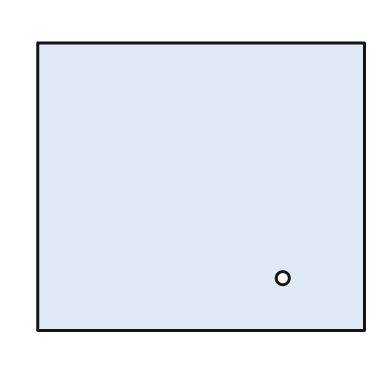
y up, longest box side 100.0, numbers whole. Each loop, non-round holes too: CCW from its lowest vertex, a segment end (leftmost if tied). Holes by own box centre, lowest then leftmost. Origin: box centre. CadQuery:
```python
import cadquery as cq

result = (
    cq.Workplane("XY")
    .moveTo(-50.0, -44.0)
    .lineTo(50.0, -44.0)
    .lineTo(50.0, 44.0)
    .lineTo(-50.0, 44.0)
    .close()
    .moveTo(25.0, -28.0)
    .circle(2.0)
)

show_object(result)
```